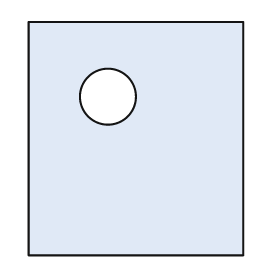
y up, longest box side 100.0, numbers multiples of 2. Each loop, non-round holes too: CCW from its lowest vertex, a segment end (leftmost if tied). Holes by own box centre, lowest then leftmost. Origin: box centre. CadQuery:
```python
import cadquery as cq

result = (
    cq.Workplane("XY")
    .moveTo(-46.0, -50.0)
    .lineTo(46.0, -50.0)
    .lineTo(46.0, 50.0)
    .lineTo(-46.0, 50.0)
    .close()
    .moveTo(-12.0, 18.0)
    .circle(12.0)
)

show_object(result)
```